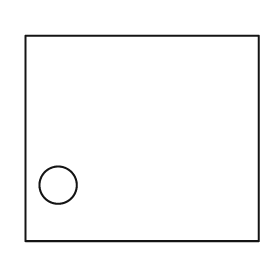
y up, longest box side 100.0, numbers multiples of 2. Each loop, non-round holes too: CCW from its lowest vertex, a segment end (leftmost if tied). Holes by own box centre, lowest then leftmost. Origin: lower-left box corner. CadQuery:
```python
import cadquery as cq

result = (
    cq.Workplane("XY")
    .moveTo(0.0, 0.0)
    .lineTo(100.0, 0.0)
    .lineTo(100.0, 88.0)
    .lineTo(0.0, 88.0)
    .close()
    .moveTo(14.0, 24.0)
    .circle(8.0)
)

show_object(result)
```